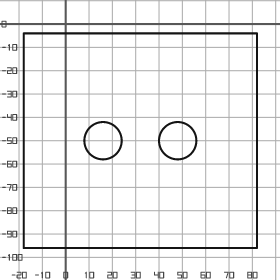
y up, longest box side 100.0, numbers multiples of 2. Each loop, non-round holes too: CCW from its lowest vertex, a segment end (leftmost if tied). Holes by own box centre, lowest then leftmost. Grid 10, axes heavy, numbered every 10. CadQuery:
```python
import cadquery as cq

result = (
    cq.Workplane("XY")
    .moveTo(-18.0, -96.0)
    .lineTo(82.0, -96.0)
    .lineTo(82.0, -4.0)
    .lineTo(-18.0, -4.0)
    .close()
    .moveTo(16.0, -50.0)
    .circle(8.0)
    .moveTo(48.0, -50.0)
    .circle(8.0)
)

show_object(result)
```